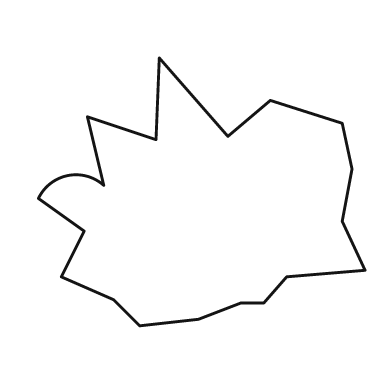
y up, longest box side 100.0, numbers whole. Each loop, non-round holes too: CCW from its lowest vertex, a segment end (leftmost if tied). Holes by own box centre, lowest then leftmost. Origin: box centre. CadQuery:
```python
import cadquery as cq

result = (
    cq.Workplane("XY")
    .moveTo(-19.0, -41.0)
    .lineTo(-1.0, -39.0)
    .lineTo(12.0, -34.0)
    .lineTo(19.0, -34.0)
    .lineTo(26.0, -26.0)
    .lineTo(50.0, -24.0)
    .lineTo(43.0, -9.0)
    .lineTo(46.0, 7.0)
    .lineTo(43.0, 21.0)
    .lineTo(21.0, 28.0)
    .lineTo(8.0, 17.0)
    .lineTo(-13.0, 41.0)
    .lineTo(-14.0, 16.0)
    .lineTo(-35.0, 23.0)
    .lineTo(-30.0, 2.0)
    .threePointArc((-41.0, 5.0), (-50.0, -2.0))
    .lineTo(-36.0, -12.0)
    .lineTo(-43.0, -26.0)
    .lineTo(-27.0, -33.0)
    .close()
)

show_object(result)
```